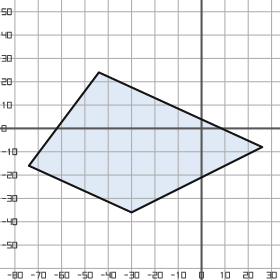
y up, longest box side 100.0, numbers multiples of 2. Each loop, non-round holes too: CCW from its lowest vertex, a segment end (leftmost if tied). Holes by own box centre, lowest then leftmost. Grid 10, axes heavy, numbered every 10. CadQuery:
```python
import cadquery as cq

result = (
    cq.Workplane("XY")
    .moveTo(-30.0, -36.0)
    .lineTo(26.0, -8.0)
    .lineTo(-44.0, 24.0)
    .lineTo(-74.0, -16.0)
    .close()
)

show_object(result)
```